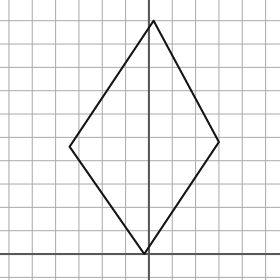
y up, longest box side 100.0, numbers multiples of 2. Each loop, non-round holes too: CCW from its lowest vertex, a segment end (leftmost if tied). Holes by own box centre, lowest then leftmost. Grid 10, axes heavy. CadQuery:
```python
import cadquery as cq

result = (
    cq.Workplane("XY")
    .moveTo(-2.0, 0.0)
    .lineTo(30.0, 48.0)
    .lineTo(2.0, 100.0)
    .lineTo(-34.0, 46.0)
    .close()
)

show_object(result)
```